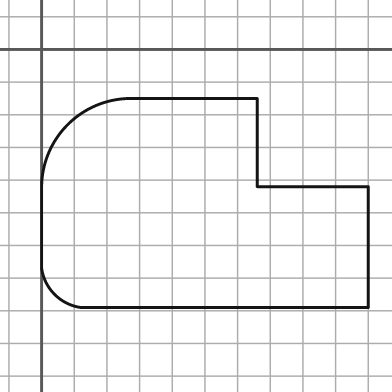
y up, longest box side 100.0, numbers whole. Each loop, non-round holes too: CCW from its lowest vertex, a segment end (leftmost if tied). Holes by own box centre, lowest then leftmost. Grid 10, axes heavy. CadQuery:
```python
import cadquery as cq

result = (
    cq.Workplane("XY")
    .moveTo(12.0, -79.0)
    .lineTo(100.0, -79.0)
    .lineTo(100.0, -42.0)
    .lineTo(66.0, -42.0)
    .lineTo(66.0, -15.0)
    .lineTo(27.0, -15.0)
    .threePointArc((8.0, -23.0), (0.0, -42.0))
    .lineTo(0.0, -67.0)
    .threePointArc((4.0, -75.0), (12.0, -79.0))
    .close()
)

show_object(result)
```